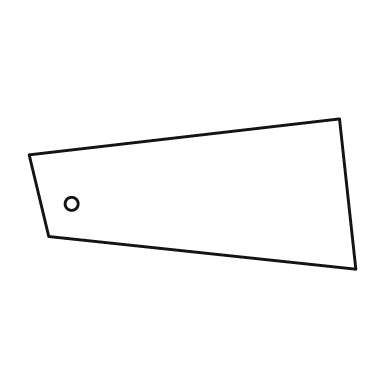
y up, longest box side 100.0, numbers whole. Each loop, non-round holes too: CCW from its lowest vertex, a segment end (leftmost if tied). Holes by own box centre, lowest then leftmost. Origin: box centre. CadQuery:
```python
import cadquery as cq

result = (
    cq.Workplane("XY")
    .moveTo(50.0, -23.0)
    .lineTo(45.0, 23.0)
    .lineTo(-50.0, 12.0)
    .lineTo(-44.0, -13.0)
    .close()
    .moveTo(-37.0, -3.0)
    .circle(2.0)
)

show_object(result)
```